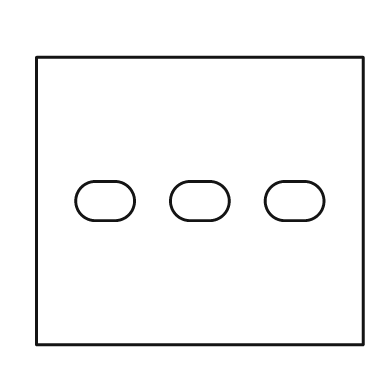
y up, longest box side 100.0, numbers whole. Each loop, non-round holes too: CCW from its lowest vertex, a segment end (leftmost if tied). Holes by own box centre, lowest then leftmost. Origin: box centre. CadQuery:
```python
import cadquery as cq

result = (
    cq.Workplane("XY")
    .moveTo(-50.0, -44.0)
    .lineTo(50.0, -44.0)
    .lineTo(50.0, 44.0)
    .lineTo(-50.0, 44.0)
    .close()
    .moveTo(-32.0, -6.0)
    .lineTo(-26.0, -6.0)
    .threePointArc((-20.0, 0.0), (-26.0, 6.0))
    .lineTo(-32.0, 6.0)
    .threePointArc((-38.0, 0.0), (-32.0, -6.0))
    .close()
    .moveTo(-3.0, -6.0)
    .lineTo(3.0, -6.0)
    .threePointArc((9.0, 0.0), (3.0, 6.0))
    .lineTo(-3.0, 6.0)
    .threePointArc((-9.0, 0.0), (-3.0, -6.0))
    .close()
    .moveTo(26.0, -6.0)
    .lineTo(32.0, -6.0)
    .threePointArc((38.0, 0.0), (32.0, 6.0))
    .lineTo(26.0, 6.0)
    .threePointArc((20.0, 0.0), (26.0, -6.0))
    .close()
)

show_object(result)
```